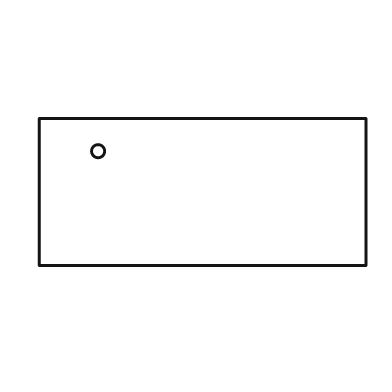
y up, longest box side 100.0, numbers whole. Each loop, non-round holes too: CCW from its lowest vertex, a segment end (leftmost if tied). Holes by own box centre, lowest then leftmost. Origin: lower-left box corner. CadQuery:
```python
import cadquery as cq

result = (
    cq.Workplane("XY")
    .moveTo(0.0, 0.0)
    .lineTo(100.0, 0.0)
    .lineTo(100.0, 45.0)
    .lineTo(0.0, 45.0)
    .close()
    .moveTo(18.0, 35.0)
    .circle(2.0)
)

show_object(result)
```